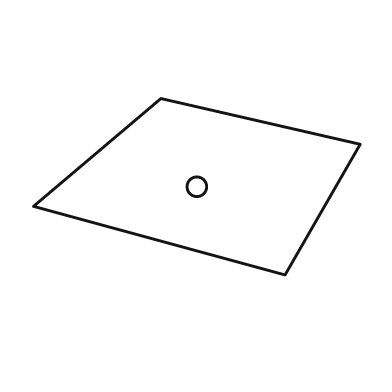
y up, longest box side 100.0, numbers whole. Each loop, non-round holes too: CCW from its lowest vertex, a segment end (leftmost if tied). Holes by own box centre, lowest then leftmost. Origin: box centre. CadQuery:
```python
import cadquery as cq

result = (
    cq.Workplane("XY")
    .moveTo(27.0, -27.0)
    .lineTo(50.0, 13.0)
    .lineTo(-11.0, 27.0)
    .lineTo(-50.0, -6.0)
    .close()
    .moveTo(0.0, 0.0)
    .circle(3.0)
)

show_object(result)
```